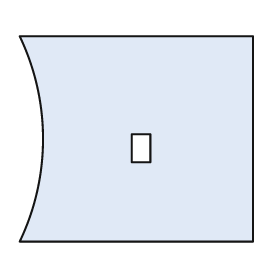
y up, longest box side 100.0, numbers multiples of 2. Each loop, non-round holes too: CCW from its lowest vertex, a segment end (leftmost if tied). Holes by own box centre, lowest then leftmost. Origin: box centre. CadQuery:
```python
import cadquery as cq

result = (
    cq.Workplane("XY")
    .moveTo(-50.0, -44.0)
    .lineTo(50.0, -44.0)
    .lineTo(50.0, 44.0)
    .lineTo(-50.0, 44.0)
    .threePointArc((-40.0, 0.0), (-50.0, -44.0))
    .close()
    .moveTo(-2.0, -10.0)
    .lineTo(6.0, -10.0)
    .lineTo(6.0, 2.0)
    .lineTo(-2.0, 2.0)
    .close()
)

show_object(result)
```